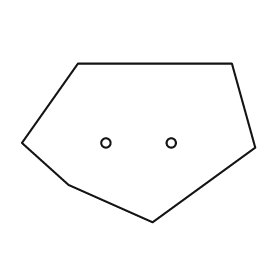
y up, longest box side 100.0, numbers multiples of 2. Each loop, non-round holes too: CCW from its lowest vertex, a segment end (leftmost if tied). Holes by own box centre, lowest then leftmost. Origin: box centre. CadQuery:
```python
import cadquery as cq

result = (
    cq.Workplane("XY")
    .moveTo(6.0, -34.0)
    .lineTo(50.0, -2.0)
    .lineTo(40.0, 34.0)
    .lineTo(-26.0, 34.0)
    .lineTo(-50.0, 0.0)
    .lineTo(-30.0, -18.0)
    .close()
    .moveTo(-14.0, 0.0)
    .circle(2.0)
    .moveTo(14.0, 0.0)
    .circle(2.0)
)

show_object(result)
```